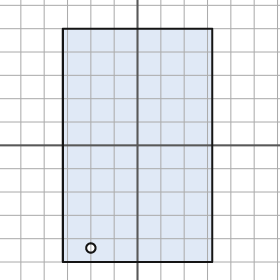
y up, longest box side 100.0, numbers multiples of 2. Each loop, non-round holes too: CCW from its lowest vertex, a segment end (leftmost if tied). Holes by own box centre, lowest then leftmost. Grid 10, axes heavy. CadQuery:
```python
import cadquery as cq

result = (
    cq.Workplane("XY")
    .moveTo(-32.0, -50.0)
    .lineTo(32.0, -50.0)
    .lineTo(32.0, 50.0)
    .lineTo(-32.0, 50.0)
    .close()
    .moveTo(-20.0, -44.0)
    .circle(2.0)
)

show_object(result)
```